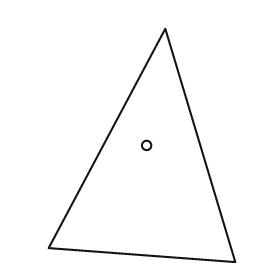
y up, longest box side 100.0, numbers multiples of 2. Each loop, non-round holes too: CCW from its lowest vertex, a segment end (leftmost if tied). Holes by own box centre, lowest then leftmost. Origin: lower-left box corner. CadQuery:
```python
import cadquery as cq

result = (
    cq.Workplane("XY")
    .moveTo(80.0, 0.0)
    .lineTo(50.0, 100.0)
    .lineTo(0.0, 6.0)
    .close()
    .moveTo(42.0, 50.0)
    .circle(2.0)
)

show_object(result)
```